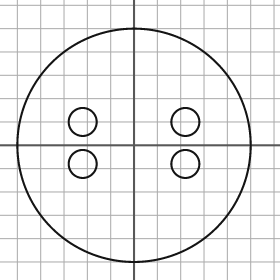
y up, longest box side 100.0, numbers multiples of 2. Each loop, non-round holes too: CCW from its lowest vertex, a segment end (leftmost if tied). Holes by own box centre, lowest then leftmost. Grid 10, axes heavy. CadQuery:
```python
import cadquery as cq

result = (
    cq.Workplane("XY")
    .moveTo(0.0, 0.0)
    .circle(50.0)
    .moveTo(-22.0, -8.0)
    .circle(6.0)
    .moveTo(22.0, -8.0)
    .circle(6.0)
    .moveTo(-22.0, 10.0)
    .circle(6.0)
    .moveTo(22.0, 10.0)
    .circle(6.0)
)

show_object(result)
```